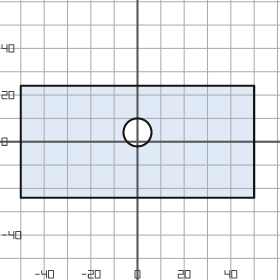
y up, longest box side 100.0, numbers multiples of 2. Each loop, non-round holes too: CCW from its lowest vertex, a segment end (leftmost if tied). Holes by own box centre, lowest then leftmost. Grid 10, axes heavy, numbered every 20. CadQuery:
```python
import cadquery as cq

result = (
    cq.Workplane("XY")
    .moveTo(-50.0, -24.0)
    .lineTo(50.0, -24.0)
    .lineTo(50.0, 24.0)
    .lineTo(-50.0, 24.0)
    .close()
    .moveTo(0.0, 4.0)
    .circle(6.0)
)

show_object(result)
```